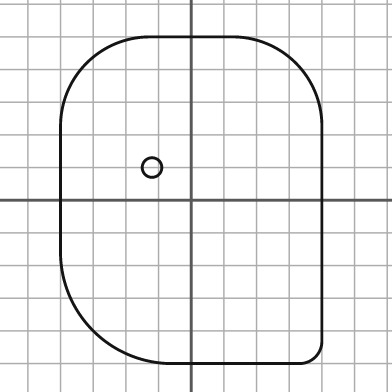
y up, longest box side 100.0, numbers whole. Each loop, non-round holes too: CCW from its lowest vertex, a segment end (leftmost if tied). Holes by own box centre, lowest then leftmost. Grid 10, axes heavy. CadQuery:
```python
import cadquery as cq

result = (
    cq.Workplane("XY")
    .moveTo(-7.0, -50.0)
    .lineTo(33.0, -50.0)
    .threePointArc((38.0, -48.0), (40.0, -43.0))
    .lineTo(40.0, 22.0)
    .threePointArc((32.0, 42.0), (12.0, 50.0))
    .lineTo(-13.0, 50.0)
    .threePointArc((-32.0, 42.0), (-40.0, 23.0))
    .lineTo(-40.0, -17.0)
    .threePointArc((-30.0, -40.0), (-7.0, -50.0))
    .close()
    .moveTo(-12.0, 10.0)
    .circle(3.0)
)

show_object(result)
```